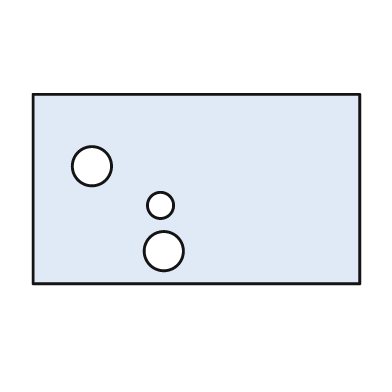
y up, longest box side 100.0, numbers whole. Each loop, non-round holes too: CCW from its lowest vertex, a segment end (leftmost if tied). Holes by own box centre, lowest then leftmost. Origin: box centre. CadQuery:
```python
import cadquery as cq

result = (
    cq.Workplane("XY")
    .moveTo(-50.0, -29.0)
    .lineTo(50.0, -29.0)
    .lineTo(50.0, 29.0)
    .lineTo(-50.0, 29.0)
    .close()
    .moveTo(-10.0, -19.0)
    .circle(6.0)
    .moveTo(-11.0, -5.0)
    .circle(4.0)
    .moveTo(-32.0, 7.0)
    .circle(6.0)
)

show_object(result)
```